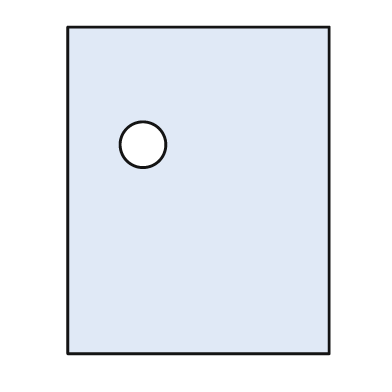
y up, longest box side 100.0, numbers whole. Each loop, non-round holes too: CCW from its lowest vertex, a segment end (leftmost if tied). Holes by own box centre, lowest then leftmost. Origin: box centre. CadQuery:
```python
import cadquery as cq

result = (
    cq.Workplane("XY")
    .moveTo(-40.0, -50.0)
    .lineTo(40.0, -50.0)
    .lineTo(40.0, 50.0)
    .lineTo(-40.0, 50.0)
    .close()
    .moveTo(-17.0, 14.0)
    .circle(7.0)
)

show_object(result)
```